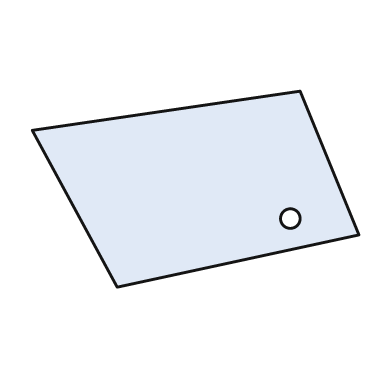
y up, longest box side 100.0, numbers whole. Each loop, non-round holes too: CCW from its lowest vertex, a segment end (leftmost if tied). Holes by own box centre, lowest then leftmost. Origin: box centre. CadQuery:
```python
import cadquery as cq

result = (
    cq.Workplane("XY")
    .moveTo(-24.0, -30.0)
    .lineTo(50.0, -14.0)
    .lineTo(32.0, 30.0)
    .lineTo(-50.0, 18.0)
    .close()
    .moveTo(29.0, -9.0)
    .circle(3.0)
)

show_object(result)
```